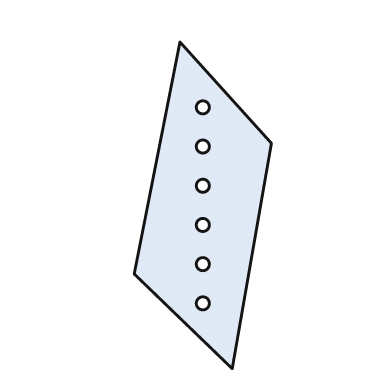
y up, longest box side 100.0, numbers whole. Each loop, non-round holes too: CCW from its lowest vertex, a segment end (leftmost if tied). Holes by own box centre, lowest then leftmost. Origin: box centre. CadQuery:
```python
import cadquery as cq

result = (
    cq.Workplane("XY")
    .moveTo(9.0, -50.0)
    .lineTo(21.0, 19.0)
    .lineTo(-7.0, 50.0)
    .lineTo(-21.0, -21.0)
    .close()
    .moveTo(0.0, -30.0)
    .circle(2.0)
    .moveTo(0.0, -18.0)
    .circle(2.0)
    .moveTo(0.0, -6.0)
    .circle(2.0)
    .moveTo(0.0, 6.0)
    .circle(2.0)
    .moveTo(0.0, 18.0)
    .circle(2.0)
    .moveTo(0.0, 30.0)
    .circle(2.0)
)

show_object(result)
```